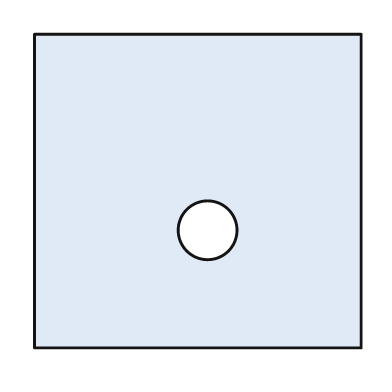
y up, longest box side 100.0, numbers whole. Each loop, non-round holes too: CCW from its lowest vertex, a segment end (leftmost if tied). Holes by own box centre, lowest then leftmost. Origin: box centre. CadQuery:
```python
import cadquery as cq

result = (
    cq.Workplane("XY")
    .moveTo(-50.0, -48.0)
    .lineTo(50.0, -48.0)
    .lineTo(50.0, 48.0)
    .lineTo(-50.0, 48.0)
    .close()
    .moveTo(3.0, -12.0)
    .circle(9.0)
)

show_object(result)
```